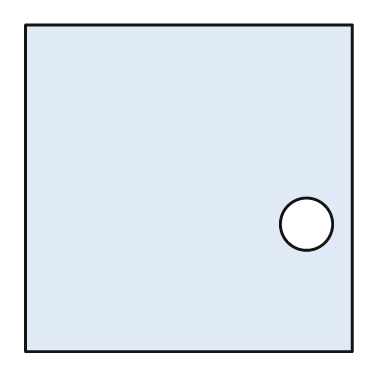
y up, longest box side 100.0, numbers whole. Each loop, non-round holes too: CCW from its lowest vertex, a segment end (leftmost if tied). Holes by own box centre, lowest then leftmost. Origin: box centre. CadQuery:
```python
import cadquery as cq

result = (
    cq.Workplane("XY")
    .moveTo(-50.0, -50.0)
    .lineTo(50.0, -50.0)
    .lineTo(50.0, 50.0)
    .lineTo(-50.0, 50.0)
    .close()
    .moveTo(36.0, -11.0)
    .circle(8.0)
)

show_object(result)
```